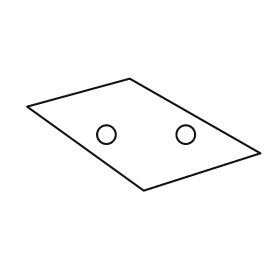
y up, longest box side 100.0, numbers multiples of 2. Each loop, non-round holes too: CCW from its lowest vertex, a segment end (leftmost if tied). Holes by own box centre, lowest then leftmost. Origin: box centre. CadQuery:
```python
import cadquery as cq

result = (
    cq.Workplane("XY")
    .moveTo(0.0, -24.0)
    .lineTo(50.0, -8.0)
    .lineTo(-6.0, 24.0)
    .lineTo(-50.0, 12.0)
    .close()
    .moveTo(-16.0, 0.0)
    .circle(4.0)
    .moveTo(18.0, 0.0)
    .circle(4.0)
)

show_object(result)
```